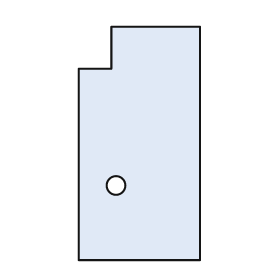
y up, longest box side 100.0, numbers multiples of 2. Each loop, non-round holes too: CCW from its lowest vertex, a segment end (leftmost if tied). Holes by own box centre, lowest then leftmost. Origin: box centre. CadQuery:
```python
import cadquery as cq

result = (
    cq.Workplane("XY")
    .moveTo(-26.0, -50.0)
    .lineTo(26.0, -50.0)
    .lineTo(26.0, 50.0)
    .lineTo(-12.0, 50.0)
    .lineTo(-12.0, 32.0)
    .lineTo(-26.0, 32.0)
    .close()
    .moveTo(-10.0, -18.0)
    .circle(4.0)
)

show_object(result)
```